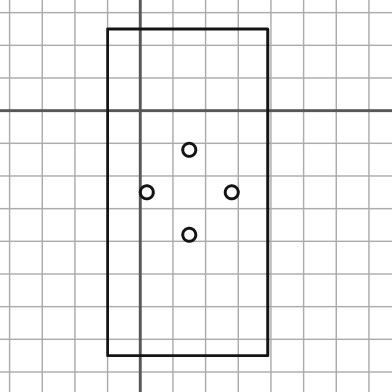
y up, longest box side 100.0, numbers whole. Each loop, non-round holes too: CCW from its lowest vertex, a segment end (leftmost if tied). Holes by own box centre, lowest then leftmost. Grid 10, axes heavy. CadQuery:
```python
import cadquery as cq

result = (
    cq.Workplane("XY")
    .moveTo(-10.0, -75.0)
    .lineTo(39.0, -75.0)
    .lineTo(39.0, 25.0)
    .lineTo(-10.0, 25.0)
    .close()
    .moveTo(15.0, -38.0)
    .circle(2.0)
    .moveTo(2.0, -25.0)
    .circle(2.0)
    .moveTo(28.0, -25.0)
    .circle(2.0)
    .moveTo(15.0, -12.0)
    .circle(2.0)
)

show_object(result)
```